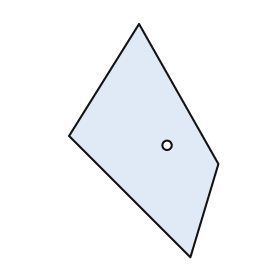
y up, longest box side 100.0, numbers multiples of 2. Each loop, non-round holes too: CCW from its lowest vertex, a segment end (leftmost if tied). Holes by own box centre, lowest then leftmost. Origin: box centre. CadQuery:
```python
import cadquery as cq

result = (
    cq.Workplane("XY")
    .moveTo(20.0, -50.0)
    .lineTo(32.0, -10.0)
    .lineTo(-2.0, 50.0)
    .lineTo(-32.0, 2.0)
    .close()
    .moveTo(10.0, -2.0)
    .circle(2.0)
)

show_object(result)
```